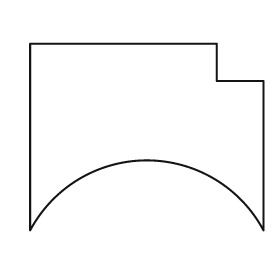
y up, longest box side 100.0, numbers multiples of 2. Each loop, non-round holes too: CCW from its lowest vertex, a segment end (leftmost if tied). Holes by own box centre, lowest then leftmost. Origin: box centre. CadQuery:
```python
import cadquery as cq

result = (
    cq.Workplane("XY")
    .moveTo(-50.0, -40.0)
    .threePointArc((0.0, -10.0), (50.0, -40.0))
    .lineTo(50.0, 24.0)
    .lineTo(30.0, 24.0)
    .lineTo(30.0, 40.0)
    .lineTo(-50.0, 40.0)
    .close()
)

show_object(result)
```